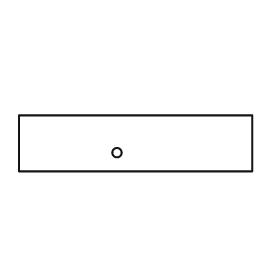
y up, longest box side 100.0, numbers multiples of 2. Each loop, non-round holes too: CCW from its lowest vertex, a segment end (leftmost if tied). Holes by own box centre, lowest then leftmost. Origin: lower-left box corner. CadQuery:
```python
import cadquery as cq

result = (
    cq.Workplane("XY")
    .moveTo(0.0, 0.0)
    .lineTo(100.0, 0.0)
    .lineTo(100.0, 24.0)
    .lineTo(0.0, 24.0)
    .close()
    .moveTo(42.0, 8.0)
    .circle(2.0)
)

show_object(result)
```